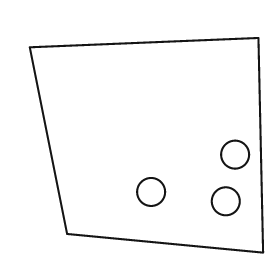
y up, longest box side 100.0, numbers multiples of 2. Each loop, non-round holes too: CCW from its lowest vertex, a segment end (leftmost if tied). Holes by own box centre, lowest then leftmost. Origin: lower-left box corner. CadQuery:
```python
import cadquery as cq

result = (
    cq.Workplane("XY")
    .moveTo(100.0, 0.0)
    .lineTo(98.0, 92.0)
    .lineTo(0.0, 88.0)
    .lineTo(16.0, 8.0)
    .close()
    .moveTo(84.0, 22.0)
    .circle(6.0)
    .moveTo(52.0, 26.0)
    .circle(6.0)
    .moveTo(88.0, 42.0)
    .circle(6.0)
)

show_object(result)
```